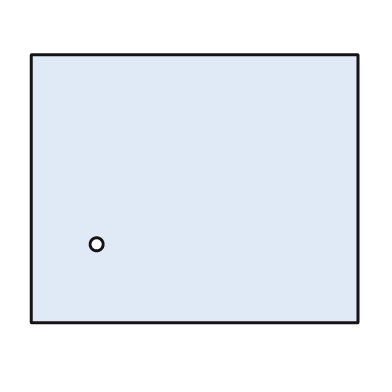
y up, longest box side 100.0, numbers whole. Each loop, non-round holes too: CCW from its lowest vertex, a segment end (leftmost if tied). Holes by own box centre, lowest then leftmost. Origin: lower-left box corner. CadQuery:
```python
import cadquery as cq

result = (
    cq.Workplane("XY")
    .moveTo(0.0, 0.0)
    .lineTo(100.0, 0.0)
    .lineTo(100.0, 82.0)
    .lineTo(0.0, 82.0)
    .close()
    .moveTo(20.0, 24.0)
    .circle(2.0)
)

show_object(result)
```